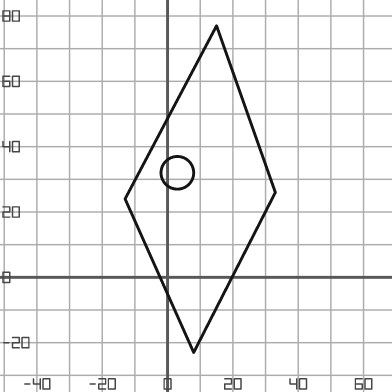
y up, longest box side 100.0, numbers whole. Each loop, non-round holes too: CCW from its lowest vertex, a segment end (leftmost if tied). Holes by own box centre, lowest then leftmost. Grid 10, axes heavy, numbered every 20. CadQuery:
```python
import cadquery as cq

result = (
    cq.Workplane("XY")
    .moveTo(8.0, -23.0)
    .lineTo(33.0, 26.0)
    .lineTo(15.0, 77.0)
    .lineTo(-13.0, 24.0)
    .close()
    .moveTo(3.0, 32.0)
    .circle(5.0)
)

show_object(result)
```